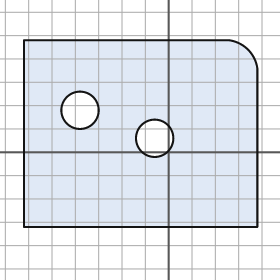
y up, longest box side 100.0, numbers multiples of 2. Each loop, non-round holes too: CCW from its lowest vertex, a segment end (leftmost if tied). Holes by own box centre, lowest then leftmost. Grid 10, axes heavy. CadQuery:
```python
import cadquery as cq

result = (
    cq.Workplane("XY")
    .moveTo(-62.0, -32.0)
    .lineTo(38.0, -32.0)
    .lineTo(38.0, 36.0)
    .threePointArc((34.0, 44.0), (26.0, 48.0))
    .lineTo(-62.0, 48.0)
    .close()
    .moveTo(-6.0, 6.0)
    .circle(8.0)
    .moveTo(-38.0, 18.0)
    .circle(8.0)
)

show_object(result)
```